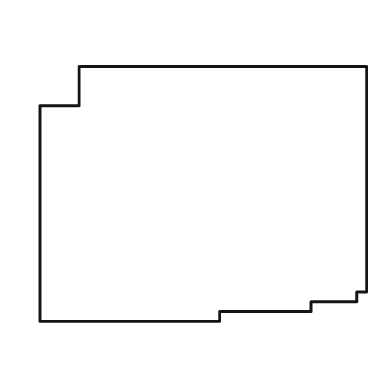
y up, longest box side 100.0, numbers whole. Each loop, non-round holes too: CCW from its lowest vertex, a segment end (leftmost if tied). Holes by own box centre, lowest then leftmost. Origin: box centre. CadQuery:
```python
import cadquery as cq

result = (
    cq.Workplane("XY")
    .moveTo(-50.0, -39.0)
    .lineTo(5.0, -39.0)
    .lineTo(5.0, -36.0)
    .lineTo(33.0, -36.0)
    .lineTo(33.0, -33.0)
    .lineTo(47.0, -33.0)
    .lineTo(47.0, -30.0)
    .lineTo(50.0, -30.0)
    .lineTo(50.0, 39.0)
    .lineTo(-38.0, 39.0)
    .lineTo(-38.0, 27.0)
    .lineTo(-50.0, 27.0)
    .close()
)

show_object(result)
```